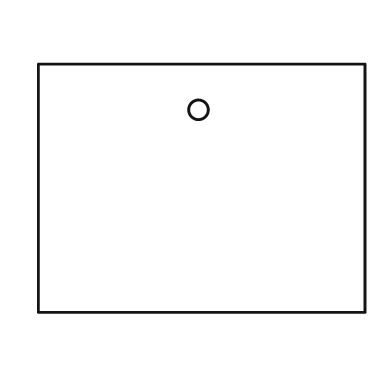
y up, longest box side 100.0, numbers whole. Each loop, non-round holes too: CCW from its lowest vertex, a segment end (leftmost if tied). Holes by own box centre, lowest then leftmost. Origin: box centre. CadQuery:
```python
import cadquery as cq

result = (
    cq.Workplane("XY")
    .moveTo(-50.0, -38.0)
    .lineTo(50.0, -38.0)
    .lineTo(50.0, 38.0)
    .lineTo(-50.0, 38.0)
    .close()
    .moveTo(-1.0, 24.0)
    .circle(3.0)
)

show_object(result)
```